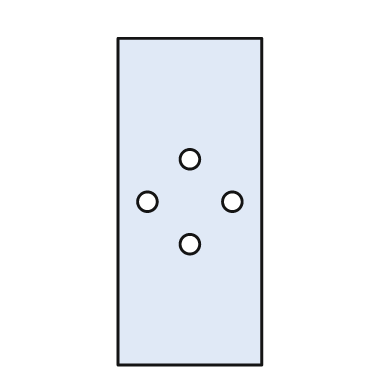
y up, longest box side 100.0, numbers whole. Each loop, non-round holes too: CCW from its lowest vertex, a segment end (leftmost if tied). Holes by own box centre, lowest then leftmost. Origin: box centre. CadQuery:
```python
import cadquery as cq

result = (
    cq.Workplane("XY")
    .moveTo(-22.0, -50.0)
    .lineTo(22.0, -50.0)
    .lineTo(22.0, 50.0)
    .lineTo(-22.0, 50.0)
    .close()
    .moveTo(0.0, -13.0)
    .circle(3.0)
    .moveTo(-13.0, 0.0)
    .circle(3.0)
    .moveTo(13.0, 0.0)
    .circle(3.0)
    .moveTo(0.0, 13.0)
    .circle(3.0)
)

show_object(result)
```